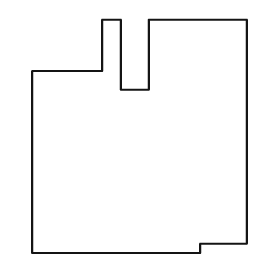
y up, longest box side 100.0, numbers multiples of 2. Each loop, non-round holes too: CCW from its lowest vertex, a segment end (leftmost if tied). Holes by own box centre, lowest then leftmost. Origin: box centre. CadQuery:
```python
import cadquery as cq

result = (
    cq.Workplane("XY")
    .moveTo(-46.0, -50.0)
    .lineTo(26.0, -50.0)
    .lineTo(26.0, -46.0)
    .lineTo(46.0, -46.0)
    .lineTo(46.0, 50.0)
    .lineTo(4.0, 50.0)
    .lineTo(4.0, 20.0)
    .lineTo(-8.0, 20.0)
    .lineTo(-8.0, 50.0)
    .lineTo(-16.0, 50.0)
    .lineTo(-16.0, 28.0)
    .lineTo(-46.0, 28.0)
    .close()
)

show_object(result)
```